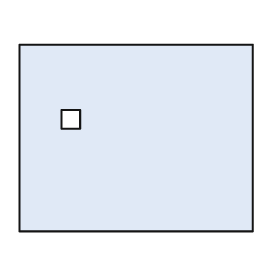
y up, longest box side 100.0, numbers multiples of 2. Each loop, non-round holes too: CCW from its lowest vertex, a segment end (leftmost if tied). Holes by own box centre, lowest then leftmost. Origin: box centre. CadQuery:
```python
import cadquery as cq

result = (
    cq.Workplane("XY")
    .moveTo(-50.0, -40.0)
    .lineTo(50.0, -40.0)
    .lineTo(50.0, 40.0)
    .lineTo(-50.0, 40.0)
    .close()
    .moveTo(-32.0, 4.0)
    .lineTo(-24.0, 4.0)
    .lineTo(-24.0, 12.0)
    .lineTo(-32.0, 12.0)
    .close()
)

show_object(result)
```